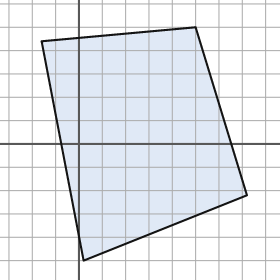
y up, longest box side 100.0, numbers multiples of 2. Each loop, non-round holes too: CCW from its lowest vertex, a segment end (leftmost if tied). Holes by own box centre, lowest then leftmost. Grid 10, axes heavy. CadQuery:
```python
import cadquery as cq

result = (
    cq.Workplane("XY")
    .moveTo(2.0, -50.0)
    .lineTo(72.0, -22.0)
    .lineTo(50.0, 50.0)
    .lineTo(-16.0, 44.0)
    .close()
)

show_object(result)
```